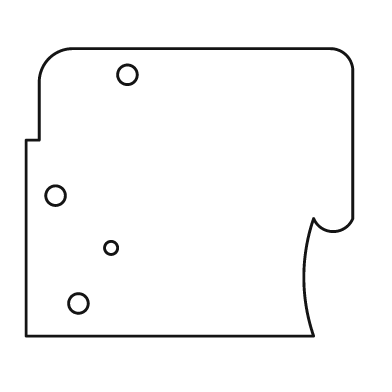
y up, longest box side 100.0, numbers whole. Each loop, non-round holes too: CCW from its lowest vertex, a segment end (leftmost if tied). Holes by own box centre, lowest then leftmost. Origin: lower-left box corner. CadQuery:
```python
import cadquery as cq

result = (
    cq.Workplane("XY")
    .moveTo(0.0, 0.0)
    .lineTo(88.0, 0.0)
    .threePointArc((85.0, 18.0), (88.0, 36.0))
    .threePointArc((94.0, 32.0), (100.0, 36.0))
    .lineTo(100.0, 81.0)
    .threePointArc((98.0, 86.0), (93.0, 88.0))
    .lineTo(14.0, 88.0)
    .threePointArc((7.0, 85.0), (4.0, 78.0))
    .lineTo(4.0, 60.0)
    .lineTo(0.0, 60.0)
    .close()
    .moveTo(16.0, 10.0)
    .circle(3.0)
    .moveTo(26.0, 27.0)
    .circle(2.0)
    .moveTo(9.0, 43.0)
    .circle(3.0)
    .moveTo(31.0, 80.0)
    .circle(3.0)
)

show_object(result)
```